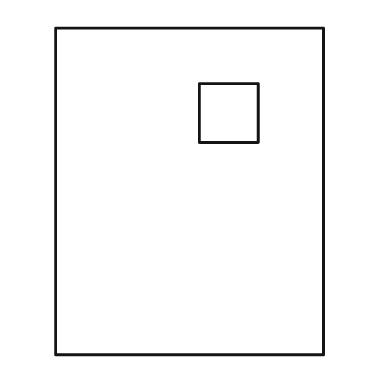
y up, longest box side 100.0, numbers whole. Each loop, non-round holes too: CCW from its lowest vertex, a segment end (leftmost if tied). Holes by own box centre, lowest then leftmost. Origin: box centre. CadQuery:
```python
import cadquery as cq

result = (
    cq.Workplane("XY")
    .moveTo(-41.0, -50.0)
    .lineTo(41.0, -50.0)
    .lineTo(41.0, 50.0)
    .lineTo(-41.0, 50.0)
    .close()
    .moveTo(3.0, 15.0)
    .lineTo(21.0, 15.0)
    .lineTo(21.0, 33.0)
    .lineTo(3.0, 33.0)
    .close()
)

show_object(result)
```